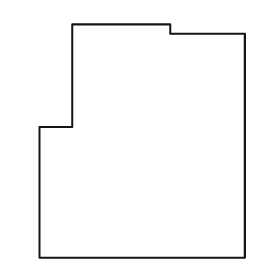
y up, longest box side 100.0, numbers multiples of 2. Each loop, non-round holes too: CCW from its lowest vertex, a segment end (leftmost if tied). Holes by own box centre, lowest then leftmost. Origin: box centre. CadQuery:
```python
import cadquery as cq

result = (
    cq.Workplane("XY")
    .moveTo(-44.0, -50.0)
    .lineTo(44.0, -50.0)
    .lineTo(44.0, 46.0)
    .lineTo(12.0, 46.0)
    .lineTo(12.0, 50.0)
    .lineTo(-30.0, 50.0)
    .lineTo(-30.0, 6.0)
    .lineTo(-44.0, 6.0)
    .close()
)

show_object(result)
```